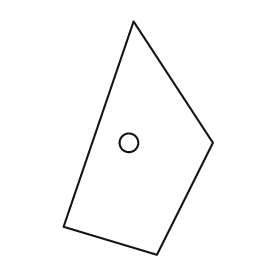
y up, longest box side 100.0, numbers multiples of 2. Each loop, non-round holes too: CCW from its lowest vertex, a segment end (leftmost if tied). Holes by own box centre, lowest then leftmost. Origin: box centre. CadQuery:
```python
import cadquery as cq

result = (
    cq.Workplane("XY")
    .moveTo(8.0, -50.0)
    .lineTo(32.0, -2.0)
    .lineTo(-2.0, 50.0)
    .lineTo(-32.0, -38.0)
    .close()
    .moveTo(-4.0, -2.0)
    .circle(4.0)
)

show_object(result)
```